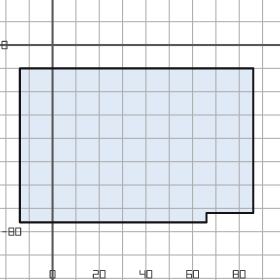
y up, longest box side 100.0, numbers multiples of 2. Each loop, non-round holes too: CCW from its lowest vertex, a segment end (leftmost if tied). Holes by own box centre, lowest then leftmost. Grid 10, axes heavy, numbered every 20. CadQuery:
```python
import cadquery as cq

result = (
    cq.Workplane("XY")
    .moveTo(-14.0, -76.0)
    .lineTo(66.0, -76.0)
    .lineTo(66.0, -72.0)
    .lineTo(86.0, -72.0)
    .lineTo(86.0, -10.0)
    .lineTo(-14.0, -10.0)
    .close()
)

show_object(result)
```